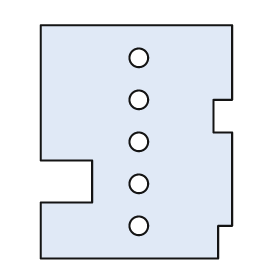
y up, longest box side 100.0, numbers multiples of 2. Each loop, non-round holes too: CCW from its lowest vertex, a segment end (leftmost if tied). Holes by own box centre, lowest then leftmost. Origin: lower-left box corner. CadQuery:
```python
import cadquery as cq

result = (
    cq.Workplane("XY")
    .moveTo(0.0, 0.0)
    .lineTo(76.0, 0.0)
    .lineTo(76.0, 14.0)
    .lineTo(82.0, 14.0)
    .lineTo(82.0, 54.0)
    .lineTo(74.0, 54.0)
    .lineTo(74.0, 68.0)
    .lineTo(82.0, 68.0)
    .lineTo(82.0, 100.0)
    .lineTo(0.0, 100.0)
    .lineTo(0.0, 42.0)
    .lineTo(22.0, 42.0)
    .lineTo(22.0, 24.0)
    .lineTo(0.0, 24.0)
    .close()
    .moveTo(42.0, 14.0)
    .circle(4.0)
    .moveTo(42.0, 32.0)
    .circle(4.0)
    .moveTo(42.0, 50.0)
    .circle(4.0)
    .moveTo(42.0, 68.0)
    .circle(4.0)
    .moveTo(42.0, 86.0)
    .circle(4.0)
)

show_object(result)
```